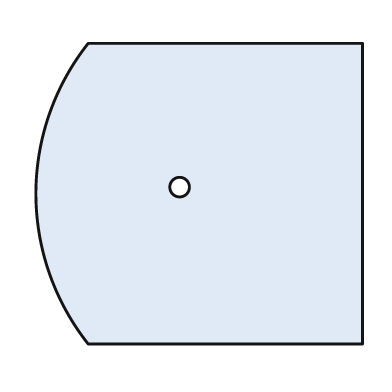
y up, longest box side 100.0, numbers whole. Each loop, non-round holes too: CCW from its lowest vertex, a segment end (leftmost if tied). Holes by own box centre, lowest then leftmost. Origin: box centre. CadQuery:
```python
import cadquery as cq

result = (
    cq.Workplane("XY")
    .moveTo(-34.0, -46.0)
    .lineTo(50.0, -46.0)
    .lineTo(50.0, 46.0)
    .lineTo(-34.0, 46.0)
    .threePointArc((-50.0, 0.0), (-34.0, -46.0))
    .close()
    .moveTo(-6.0, 2.0)
    .circle(3.0)
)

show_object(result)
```